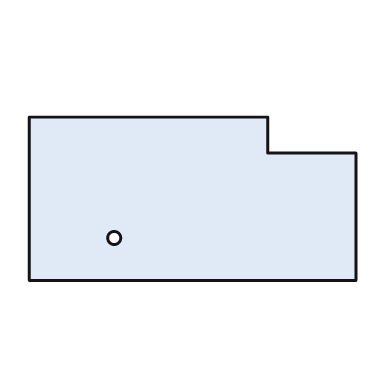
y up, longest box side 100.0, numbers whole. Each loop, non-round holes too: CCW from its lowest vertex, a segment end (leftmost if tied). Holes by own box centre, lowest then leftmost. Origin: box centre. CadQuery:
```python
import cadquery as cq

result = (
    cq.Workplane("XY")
    .moveTo(-50.0, -25.0)
    .lineTo(50.0, -25.0)
    .lineTo(50.0, 14.0)
    .lineTo(23.0, 14.0)
    .lineTo(23.0, 25.0)
    .lineTo(-50.0, 25.0)
    .close()
    .moveTo(-24.0, -12.0)
    .circle(2.0)
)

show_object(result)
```